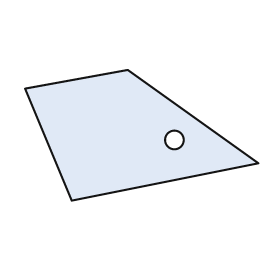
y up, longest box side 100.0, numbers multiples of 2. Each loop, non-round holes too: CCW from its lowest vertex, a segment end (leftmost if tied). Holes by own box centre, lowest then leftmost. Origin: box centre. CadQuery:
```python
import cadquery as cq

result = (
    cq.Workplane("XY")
    .moveTo(-30.0, -28.0)
    .lineTo(50.0, -12.0)
    .lineTo(-6.0, 28.0)
    .lineTo(-50.0, 20.0)
    .close()
    .moveTo(14.0, -2.0)
    .circle(4.0)
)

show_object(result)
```